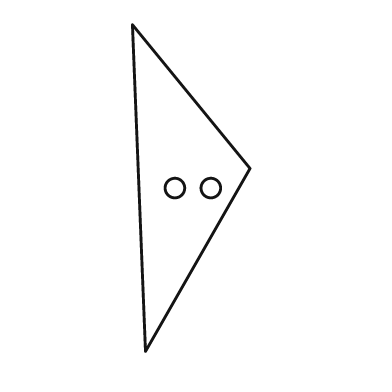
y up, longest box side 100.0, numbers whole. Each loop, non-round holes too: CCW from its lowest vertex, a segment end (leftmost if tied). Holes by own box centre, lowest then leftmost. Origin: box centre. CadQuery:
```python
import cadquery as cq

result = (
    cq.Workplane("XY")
    .moveTo(-14.0, -50.0)
    .lineTo(18.0, 6.0)
    .lineTo(-18.0, 50.0)
    .close()
    .moveTo(-5.0, 0.0)
    .circle(3.0)
    .moveTo(6.0, 0.0)
    .circle(3.0)
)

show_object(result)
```